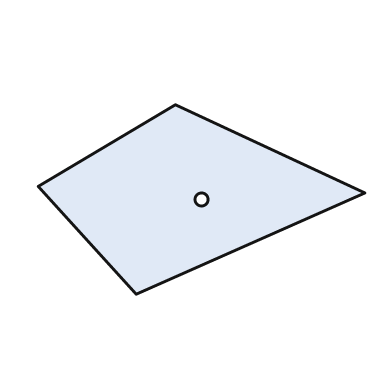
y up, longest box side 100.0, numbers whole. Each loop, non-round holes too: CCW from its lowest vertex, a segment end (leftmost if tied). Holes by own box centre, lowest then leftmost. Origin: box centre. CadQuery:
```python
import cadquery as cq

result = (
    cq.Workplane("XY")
    .moveTo(-20.0, -29.0)
    .lineTo(50.0, 2.0)
    .lineTo(-8.0, 29.0)
    .lineTo(-50.0, 4.0)
    .close()
    .moveTo(0.0, 0.0)
    .circle(2.0)
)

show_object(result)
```